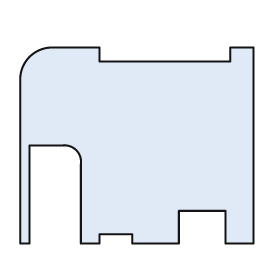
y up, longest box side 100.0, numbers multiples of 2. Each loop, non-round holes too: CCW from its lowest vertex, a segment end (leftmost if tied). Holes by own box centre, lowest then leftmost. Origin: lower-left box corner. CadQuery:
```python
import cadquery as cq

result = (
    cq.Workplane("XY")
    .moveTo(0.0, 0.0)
    .lineTo(4.0, 0.0)
    .lineTo(4.0, 42.0)
    .lineTo(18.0, 42.0)
    .threePointArc((24.0, 40.0), (26.0, 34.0))
    .lineTo(26.0, 0.0)
    .lineTo(34.0, 0.0)
    .lineTo(34.0, 4.0)
    .lineTo(48.0, 4.0)
    .lineTo(48.0, 0.0)
    .lineTo(68.0, 0.0)
    .lineTo(68.0, 14.0)
    .lineTo(88.0, 14.0)
    .lineTo(88.0, 0.0)
    .lineTo(100.0, 0.0)
    .lineTo(100.0, 84.0)
    .lineTo(90.0, 84.0)
    .lineTo(90.0, 78.0)
    .lineTo(34.0, 78.0)
    .lineTo(34.0, 84.0)
    .lineTo(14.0, 84.0)
    .threePointArc((4.0, 80.0), (0.0, 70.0))
    .close()
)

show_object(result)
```